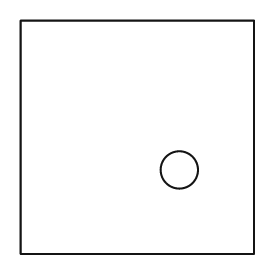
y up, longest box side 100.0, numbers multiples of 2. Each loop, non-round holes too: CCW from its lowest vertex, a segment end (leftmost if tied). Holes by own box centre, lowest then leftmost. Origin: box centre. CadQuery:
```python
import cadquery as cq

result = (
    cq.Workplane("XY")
    .moveTo(-50.0, -50.0)
    .lineTo(50.0, -50.0)
    .lineTo(50.0, 50.0)
    .lineTo(-50.0, 50.0)
    .close()
    .moveTo(18.0, -14.0)
    .circle(8.0)
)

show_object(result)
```